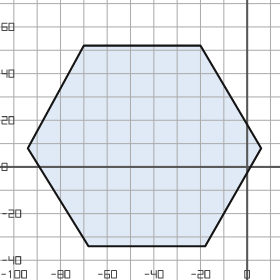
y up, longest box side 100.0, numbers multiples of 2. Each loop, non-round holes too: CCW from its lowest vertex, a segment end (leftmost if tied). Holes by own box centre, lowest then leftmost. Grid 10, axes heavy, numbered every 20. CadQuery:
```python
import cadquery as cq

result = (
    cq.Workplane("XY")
    .moveTo(-68.0, -34.0)
    .lineTo(-18.0, -34.0)
    .lineTo(6.0, 8.0)
    .lineTo(-20.0, 52.0)
    .lineTo(-70.0, 52.0)
    .lineTo(-94.0, 8.0)
    .close()
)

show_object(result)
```